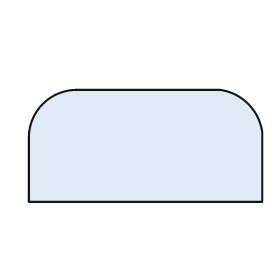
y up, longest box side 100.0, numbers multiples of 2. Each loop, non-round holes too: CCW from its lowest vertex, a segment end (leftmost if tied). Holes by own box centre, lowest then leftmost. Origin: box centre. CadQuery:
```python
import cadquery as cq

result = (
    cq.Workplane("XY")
    .moveTo(-50.0, -24.0)
    .lineTo(50.0, -24.0)
    .lineTo(50.0, 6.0)
    .threePointArc((44.0, 18.0), (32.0, 24.0))
    .lineTo(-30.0, 24.0)
    .threePointArc((-44.0, 18.0), (-50.0, 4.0))
    .close()
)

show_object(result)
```